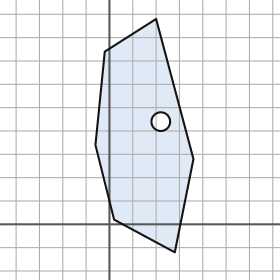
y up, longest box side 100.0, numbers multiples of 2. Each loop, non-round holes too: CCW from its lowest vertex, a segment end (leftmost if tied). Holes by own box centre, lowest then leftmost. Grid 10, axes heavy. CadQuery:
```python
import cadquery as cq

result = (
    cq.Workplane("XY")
    .moveTo(28.0, -12.0)
    .lineTo(36.0, 28.0)
    .lineTo(20.0, 88.0)
    .lineTo(-2.0, 74.0)
    .lineTo(-6.0, 34.0)
    .lineTo(2.0, 2.0)
    .close()
    .moveTo(22.0, 44.0)
    .circle(4.0)
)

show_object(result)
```